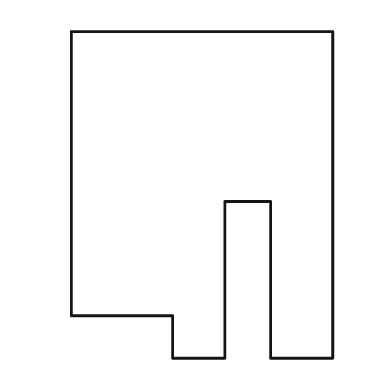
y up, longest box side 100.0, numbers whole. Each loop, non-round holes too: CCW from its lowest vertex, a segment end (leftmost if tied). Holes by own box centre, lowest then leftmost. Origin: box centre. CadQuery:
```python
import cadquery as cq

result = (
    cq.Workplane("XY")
    .moveTo(-9.0, -50.0)
    .lineTo(7.0, -50.0)
    .lineTo(7.0, -2.0)
    .lineTo(21.0, -2.0)
    .lineTo(21.0, -50.0)
    .lineTo(40.0, -50.0)
    .lineTo(40.0, 50.0)
    .lineTo(-40.0, 50.0)
    .lineTo(-40.0, -37.0)
    .lineTo(-9.0, -37.0)
    .close()
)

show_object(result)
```